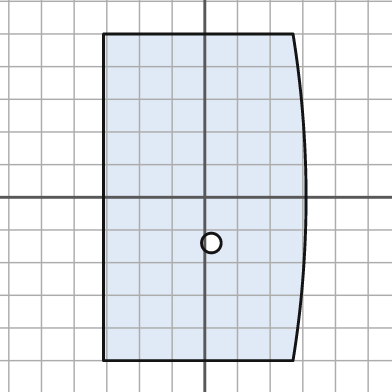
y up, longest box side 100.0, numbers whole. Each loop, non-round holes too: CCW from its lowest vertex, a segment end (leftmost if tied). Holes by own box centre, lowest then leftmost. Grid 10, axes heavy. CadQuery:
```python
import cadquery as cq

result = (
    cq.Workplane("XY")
    .moveTo(-31.0, -50.0)
    .lineTo(27.0, -50.0)
    .threePointArc((31.0, 0.0), (27.0, 50.0))
    .lineTo(-31.0, 50.0)
    .close()
    .moveTo(2.0, -14.0)
    .circle(3.0)
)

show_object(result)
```